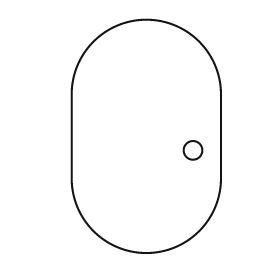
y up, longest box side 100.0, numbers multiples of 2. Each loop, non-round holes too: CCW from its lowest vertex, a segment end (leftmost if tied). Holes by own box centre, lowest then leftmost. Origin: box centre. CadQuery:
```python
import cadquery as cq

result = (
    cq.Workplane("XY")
    .moveTo(-32.0, -18.0)
    .threePointArc((0.0, -50.0), (32.0, -18.0))
    .lineTo(32.0, 18.0)
    .threePointArc((0.0, 50.0), (-32.0, 18.0))
    .close()
    .moveTo(20.0, -6.0)
    .circle(4.0)
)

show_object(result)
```